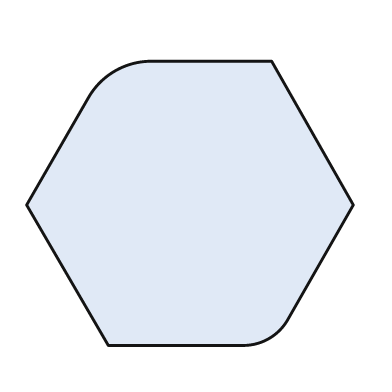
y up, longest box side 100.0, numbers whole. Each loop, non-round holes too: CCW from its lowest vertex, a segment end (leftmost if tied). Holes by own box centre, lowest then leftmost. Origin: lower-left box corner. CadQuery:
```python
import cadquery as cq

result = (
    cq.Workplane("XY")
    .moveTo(25.0, 0.0)
    .lineTo(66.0, 0.0)
    .threePointArc((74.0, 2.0), (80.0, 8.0))
    .lineTo(100.0, 43.0)
    .lineTo(75.0, 87.0)
    .lineTo(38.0, 87.0)
    .threePointArc((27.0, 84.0), (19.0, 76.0))
    .lineTo(0.0, 43.0)
    .close()
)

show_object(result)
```